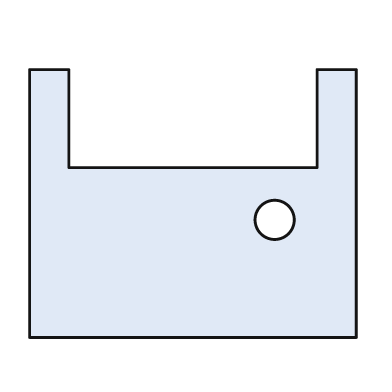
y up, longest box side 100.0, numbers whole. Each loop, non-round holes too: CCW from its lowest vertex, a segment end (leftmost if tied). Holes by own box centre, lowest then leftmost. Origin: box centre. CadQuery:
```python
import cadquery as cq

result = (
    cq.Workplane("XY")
    .moveTo(-50.0, -41.0)
    .lineTo(50.0, -41.0)
    .lineTo(50.0, 41.0)
    .lineTo(38.0, 41.0)
    .lineTo(38.0, 11.0)
    .lineTo(-38.0, 11.0)
    .lineTo(-38.0, 41.0)
    .lineTo(-50.0, 41.0)
    .close()
    .moveTo(25.0, -5.0)
    .circle(6.0)
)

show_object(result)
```